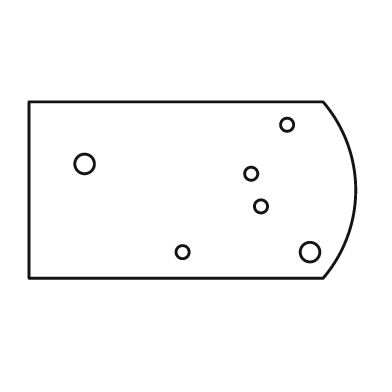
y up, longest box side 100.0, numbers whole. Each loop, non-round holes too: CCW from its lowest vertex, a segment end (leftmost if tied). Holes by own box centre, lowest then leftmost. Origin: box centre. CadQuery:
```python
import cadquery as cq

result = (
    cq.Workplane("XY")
    .moveTo(-50.0, -27.0)
    .lineTo(40.0, -27.0)
    .threePointArc((50.0, 0.0), (40.0, 27.0))
    .lineTo(-50.0, 27.0)
    .close()
    .moveTo(-3.0, -19.0)
    .circle(2.0)
    .moveTo(36.0, -19.0)
    .circle(3.0)
    .moveTo(21.0, -5.0)
    .circle(2.0)
    .moveTo(18.0, 5.0)
    .circle(2.0)
    .moveTo(-33.0, 8.0)
    .circle(3.0)
    .moveTo(29.0, 20.0)
    .circle(2.0)
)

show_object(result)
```